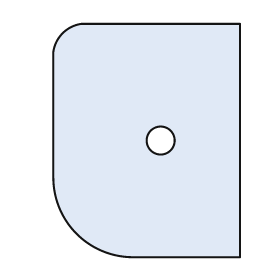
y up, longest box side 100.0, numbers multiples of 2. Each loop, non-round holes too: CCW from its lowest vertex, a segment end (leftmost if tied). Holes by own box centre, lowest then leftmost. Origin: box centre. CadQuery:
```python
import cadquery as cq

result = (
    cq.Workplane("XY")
    .moveTo(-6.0, -50.0)
    .lineTo(40.0, -50.0)
    .lineTo(40.0, 50.0)
    .lineTo(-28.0, 50.0)
    .threePointArc((-36.0, 46.0), (-40.0, 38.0))
    .lineTo(-40.0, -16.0)
    .threePointArc((-30.0, -40.0), (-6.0, -50.0))
    .close()
    .moveTo(6.0, 0.0)
    .circle(6.0)
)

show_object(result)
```